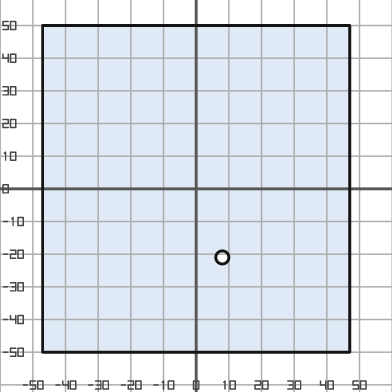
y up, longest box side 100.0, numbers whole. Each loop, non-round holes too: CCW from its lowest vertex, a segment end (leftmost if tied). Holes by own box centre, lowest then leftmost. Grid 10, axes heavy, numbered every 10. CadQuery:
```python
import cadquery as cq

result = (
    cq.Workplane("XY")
    .moveTo(-47.0, -50.0)
    .lineTo(47.0, -50.0)
    .lineTo(47.0, 50.0)
    .lineTo(-47.0, 50.0)
    .close()
    .moveTo(8.0, -21.0)
    .circle(2.0)
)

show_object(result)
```